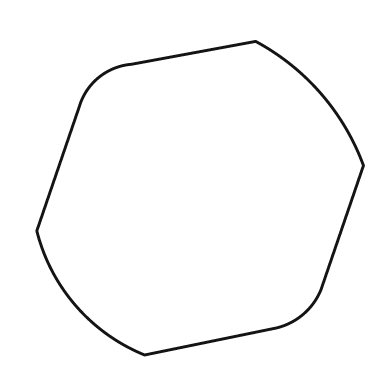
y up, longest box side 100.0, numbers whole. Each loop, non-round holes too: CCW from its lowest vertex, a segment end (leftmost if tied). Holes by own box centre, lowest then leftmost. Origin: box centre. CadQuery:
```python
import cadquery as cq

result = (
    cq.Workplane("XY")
    .moveTo(-17.0, -48.0)
    .lineTo(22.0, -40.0)
    .threePointArc((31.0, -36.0), (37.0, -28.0))
    .lineTo(50.0, 10.0)
    .threePointArc((37.0, 32.0), (17.0, 48.0))
    .lineTo(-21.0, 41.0)
    .threePointArc((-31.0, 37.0), (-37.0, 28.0))
    .lineTo(-50.0, -10.0)
    .threePointArc((-38.0, -33.0), (-17.0, -48.0))
    .close()
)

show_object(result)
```